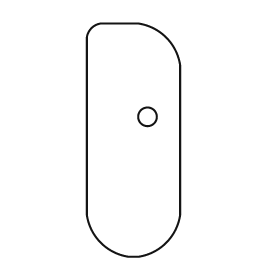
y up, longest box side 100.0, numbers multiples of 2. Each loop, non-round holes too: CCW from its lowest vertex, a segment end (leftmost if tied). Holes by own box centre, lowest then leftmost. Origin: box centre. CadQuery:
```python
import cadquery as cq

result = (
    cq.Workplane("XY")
    .moveTo(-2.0, -50.0)
    .lineTo(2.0, -50.0)
    .threePointArc((14.0, -44.0), (20.0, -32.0))
    .lineTo(20.0, 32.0)
    .threePointArc((14.0, 44.0), (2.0, 50.0))
    .lineTo(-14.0, 50.0)
    .threePointArc((-18.0, 48.0), (-20.0, 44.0))
    .lineTo(-20.0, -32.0)
    .threePointArc((-14.0, -44.0), (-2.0, -50.0))
    .close()
    .moveTo(6.0, 10.0)
    .circle(4.0)
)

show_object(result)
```